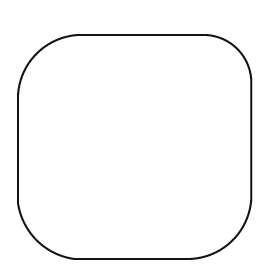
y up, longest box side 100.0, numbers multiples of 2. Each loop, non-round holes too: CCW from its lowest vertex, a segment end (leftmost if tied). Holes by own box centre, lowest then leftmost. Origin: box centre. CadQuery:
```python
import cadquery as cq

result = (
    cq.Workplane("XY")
    .moveTo(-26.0, -48.0)
    .lineTo(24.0, -48.0)
    .threePointArc((42.0, -40.0), (50.0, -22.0))
    .lineTo(50.0, 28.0)
    .threePointArc((44.0, 42.0), (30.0, 48.0))
    .lineTo(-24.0, 48.0)
    .threePointArc((-42.0, 40.0), (-50.0, 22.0))
    .lineTo(-50.0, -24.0)
    .threePointArc((-42.0, -40.0), (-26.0, -48.0))
    .close()
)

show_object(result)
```